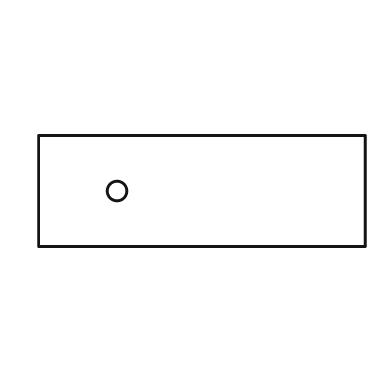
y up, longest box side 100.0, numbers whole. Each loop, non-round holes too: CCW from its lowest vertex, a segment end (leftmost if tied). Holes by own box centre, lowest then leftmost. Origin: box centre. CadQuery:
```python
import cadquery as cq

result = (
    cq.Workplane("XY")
    .moveTo(-50.0, -17.0)
    .lineTo(50.0, -17.0)
    .lineTo(50.0, 17.0)
    .lineTo(-50.0, 17.0)
    .close()
    .moveTo(-26.0, 0.0)
    .circle(3.0)
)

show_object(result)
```